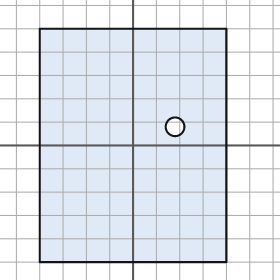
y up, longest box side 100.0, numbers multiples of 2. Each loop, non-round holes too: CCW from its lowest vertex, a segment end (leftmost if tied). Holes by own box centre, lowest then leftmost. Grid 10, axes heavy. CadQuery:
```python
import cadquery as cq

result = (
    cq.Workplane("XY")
    .moveTo(-40.0, -50.0)
    .lineTo(40.0, -50.0)
    .lineTo(40.0, 50.0)
    .lineTo(-40.0, 50.0)
    .close()
    .moveTo(18.0, 8.0)
    .circle(4.0)
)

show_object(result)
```